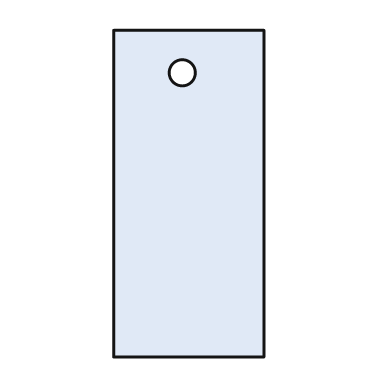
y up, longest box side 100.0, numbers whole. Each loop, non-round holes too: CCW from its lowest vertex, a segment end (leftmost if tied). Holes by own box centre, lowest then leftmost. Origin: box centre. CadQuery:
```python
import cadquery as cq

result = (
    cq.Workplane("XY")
    .moveTo(-23.0, -50.0)
    .lineTo(23.0, -50.0)
    .lineTo(23.0, 50.0)
    .lineTo(-23.0, 50.0)
    .close()
    .moveTo(-2.0, 37.0)
    .circle(4.0)
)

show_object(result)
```